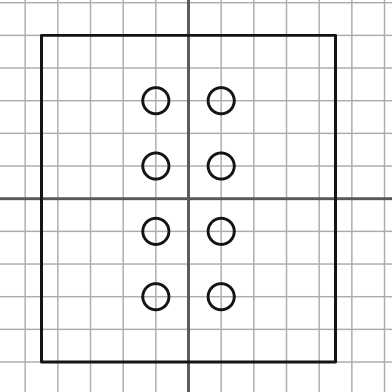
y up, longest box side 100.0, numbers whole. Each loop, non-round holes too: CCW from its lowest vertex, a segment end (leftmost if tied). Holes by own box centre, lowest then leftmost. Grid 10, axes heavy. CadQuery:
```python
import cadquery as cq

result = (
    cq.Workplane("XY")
    .moveTo(-45.0, -50.0)
    .lineTo(45.0, -50.0)
    .lineTo(45.0, 50.0)
    .lineTo(-45.0, 50.0)
    .close()
    .moveTo(-10.0, -30.0)
    .circle(4.0)
    .moveTo(10.0, -30.0)
    .circle(4.0)
    .moveTo(-10.0, -10.0)
    .circle(4.0)
    .moveTo(10.0, -10.0)
    .circle(4.0)
    .moveTo(-10.0, 10.0)
    .circle(4.0)
    .moveTo(10.0, 10.0)
    .circle(4.0)
    .moveTo(-10.0, 30.0)
    .circle(4.0)
    .moveTo(10.0, 30.0)
    .circle(4.0)
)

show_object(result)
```